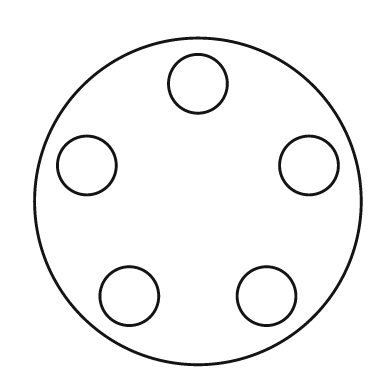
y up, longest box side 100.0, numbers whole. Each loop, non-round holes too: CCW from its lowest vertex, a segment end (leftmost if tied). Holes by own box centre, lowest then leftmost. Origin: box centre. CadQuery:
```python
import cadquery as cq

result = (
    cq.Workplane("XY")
    .moveTo(0.0, 0.0)
    .circle(50.0)
    .moveTo(-21.0, -29.0)
    .circle(9.0)
    .moveTo(21.0, -29.0)
    .circle(9.0)
    .moveTo(-34.0, 11.0)
    .circle(9.0)
    .moveTo(34.0, 11.0)
    .circle(9.0)
    .moveTo(0.0, 36.0)
    .circle(9.0)
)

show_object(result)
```